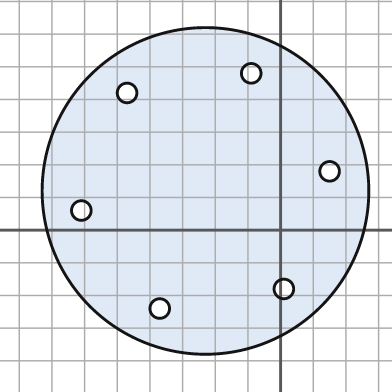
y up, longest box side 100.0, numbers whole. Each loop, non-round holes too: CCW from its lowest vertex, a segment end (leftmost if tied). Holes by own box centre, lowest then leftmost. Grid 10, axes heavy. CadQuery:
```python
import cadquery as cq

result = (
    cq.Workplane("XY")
    .moveTo(-23.0, 12.0)
    .circle(50.0)
    .moveTo(-37.0, -24.0)
    .circle(3.0)
    .moveTo(1.0, -18.0)
    .circle(3.0)
    .moveTo(-61.0, 6.0)
    .circle(3.0)
    .moveTo(15.0, 18.0)
    .circle(3.0)
    .moveTo(-47.0, 42.0)
    .circle(3.0)
    .moveTo(-9.0, 48.0)
    .circle(3.0)
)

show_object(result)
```